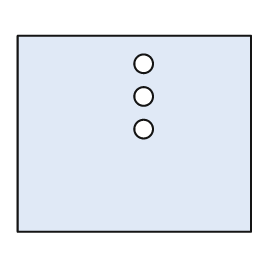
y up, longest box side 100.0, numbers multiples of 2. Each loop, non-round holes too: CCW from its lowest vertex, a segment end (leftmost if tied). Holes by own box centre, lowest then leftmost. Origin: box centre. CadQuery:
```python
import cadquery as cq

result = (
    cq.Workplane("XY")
    .moveTo(-50.0, -42.0)
    .lineTo(50.0, -42.0)
    .lineTo(50.0, 42.0)
    .lineTo(-50.0, 42.0)
    .close()
    .moveTo(4.0, 2.0)
    .circle(4.0)
    .moveTo(4.0, 16.0)
    .circle(4.0)
    .moveTo(4.0, 30.0)
    .circle(4.0)
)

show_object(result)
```